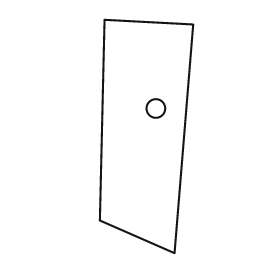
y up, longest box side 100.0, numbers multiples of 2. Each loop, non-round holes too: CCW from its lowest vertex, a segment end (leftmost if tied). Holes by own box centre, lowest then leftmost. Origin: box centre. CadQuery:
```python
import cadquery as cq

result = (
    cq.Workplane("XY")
    .moveTo(12.0, -50.0)
    .lineTo(20.0, 48.0)
    .lineTo(-18.0, 50.0)
    .lineTo(-20.0, -36.0)
    .close()
    .moveTo(4.0, 12.0)
    .circle(4.0)
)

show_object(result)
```